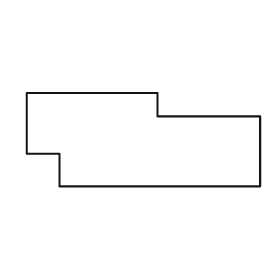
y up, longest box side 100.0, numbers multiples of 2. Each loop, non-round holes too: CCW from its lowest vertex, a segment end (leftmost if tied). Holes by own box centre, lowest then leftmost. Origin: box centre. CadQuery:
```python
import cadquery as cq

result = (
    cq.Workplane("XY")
    .moveTo(-36.0, -20.0)
    .lineTo(50.0, -20.0)
    .lineTo(50.0, 10.0)
    .lineTo(6.0, 10.0)
    .lineTo(6.0, 20.0)
    .lineTo(-50.0, 20.0)
    .lineTo(-50.0, -6.0)
    .lineTo(-36.0, -6.0)
    .close()
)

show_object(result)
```